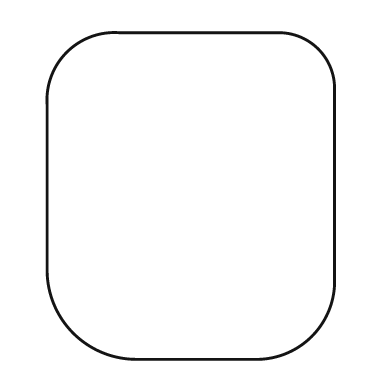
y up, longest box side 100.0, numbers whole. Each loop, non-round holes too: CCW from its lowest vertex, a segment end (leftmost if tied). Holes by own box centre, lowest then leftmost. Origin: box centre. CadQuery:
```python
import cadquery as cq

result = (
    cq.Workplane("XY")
    .moveTo(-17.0, -50.0)
    .lineTo(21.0, -50.0)
    .threePointArc((37.0, -43.0), (44.0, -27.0))
    .lineTo(44.0, 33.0)
    .threePointArc((39.0, 45.0), (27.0, 50.0))
    .lineTo(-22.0, 50.0)
    .threePointArc((-38.0, 44.0), (-44.0, 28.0))
    .lineTo(-44.0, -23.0)
    .threePointArc((-36.0, -42.0), (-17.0, -50.0))
    .close()
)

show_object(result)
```